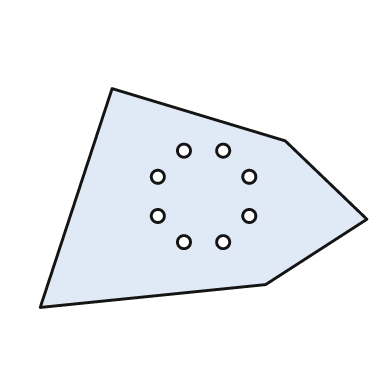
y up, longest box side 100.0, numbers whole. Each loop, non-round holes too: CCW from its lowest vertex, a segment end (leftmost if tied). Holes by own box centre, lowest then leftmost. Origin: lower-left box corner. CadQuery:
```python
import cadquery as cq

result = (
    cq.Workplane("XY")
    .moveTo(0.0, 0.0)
    .lineTo(69.0, 7.0)
    .lineTo(100.0, 27.0)
    .lineTo(75.0, 51.0)
    .lineTo(22.0, 67.0)
    .close()
    .moveTo(44.0, 20.0)
    .circle(2.0)
    .moveTo(56.0, 20.0)
    .circle(2.0)
    .moveTo(36.0, 28.0)
    .circle(2.0)
    .moveTo(64.0, 28.0)
    .circle(2.0)
    .moveTo(36.0, 40.0)
    .circle(2.0)
    .moveTo(64.0, 40.0)
    .circle(2.0)
    .moveTo(44.0, 48.0)
    .circle(2.0)
    .moveTo(56.0, 48.0)
    .circle(2.0)
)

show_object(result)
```